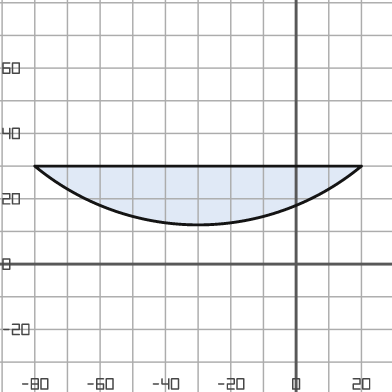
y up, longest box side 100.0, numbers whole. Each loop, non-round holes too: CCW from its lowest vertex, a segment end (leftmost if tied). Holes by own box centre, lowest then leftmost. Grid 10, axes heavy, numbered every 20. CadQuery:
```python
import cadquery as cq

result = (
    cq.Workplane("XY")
    .moveTo(-80.0, 30.0)
    .threePointArc((-30.0, 12.0), (20.0, 30.0))
    .close()
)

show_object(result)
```